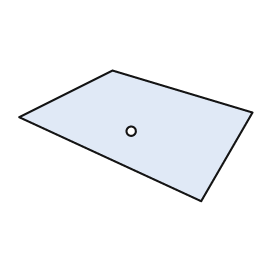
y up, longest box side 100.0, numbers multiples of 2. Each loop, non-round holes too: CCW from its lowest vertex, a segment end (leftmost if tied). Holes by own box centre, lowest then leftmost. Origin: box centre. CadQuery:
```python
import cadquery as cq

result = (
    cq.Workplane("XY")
    .moveTo(28.0, -28.0)
    .lineTo(50.0, 10.0)
    .lineTo(-10.0, 28.0)
    .lineTo(-50.0, 8.0)
    .close()
    .moveTo(-2.0, 2.0)
    .circle(2.0)
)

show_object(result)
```